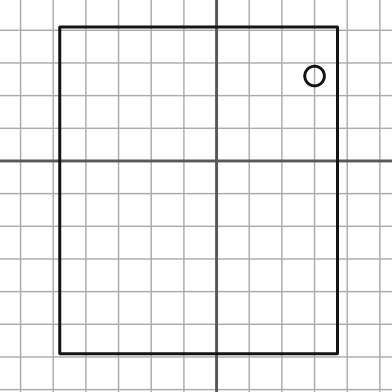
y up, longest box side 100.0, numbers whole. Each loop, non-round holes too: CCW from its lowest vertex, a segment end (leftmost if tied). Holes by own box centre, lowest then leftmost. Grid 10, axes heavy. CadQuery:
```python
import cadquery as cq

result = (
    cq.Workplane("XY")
    .moveTo(-48.0, -59.0)
    .lineTo(37.0, -59.0)
    .lineTo(37.0, 41.0)
    .lineTo(-48.0, 41.0)
    .close()
    .moveTo(30.0, 26.0)
    .circle(3.0)
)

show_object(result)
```